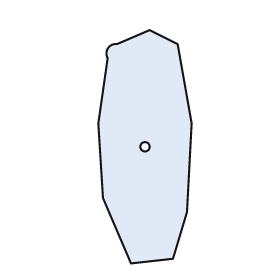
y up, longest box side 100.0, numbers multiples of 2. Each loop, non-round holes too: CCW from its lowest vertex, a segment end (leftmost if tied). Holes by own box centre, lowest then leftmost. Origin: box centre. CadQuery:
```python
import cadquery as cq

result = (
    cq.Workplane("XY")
    .moveTo(-6.0, -50.0)
    .lineTo(12.0, -48.0)
    .lineTo(18.0, -28.0)
    .lineTo(20.0, 10.0)
    .lineTo(14.0, 44.0)
    .lineTo(2.0, 50.0)
    .lineTo(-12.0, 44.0)
    .threePointArc((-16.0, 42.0), (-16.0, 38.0))
    .lineTo(-20.0, 10.0)
    .lineTo(-18.0, -22.0)
    .close()
    .moveTo(0.0, 0.0)
    .circle(2.0)
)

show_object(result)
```